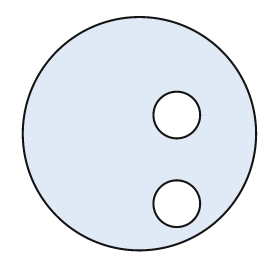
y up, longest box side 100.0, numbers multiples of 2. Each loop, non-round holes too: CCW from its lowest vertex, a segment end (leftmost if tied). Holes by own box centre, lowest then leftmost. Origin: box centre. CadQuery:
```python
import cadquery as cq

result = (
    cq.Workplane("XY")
    .moveTo(0.0, 0.0)
    .circle(50.0)
    .moveTo(16.0, -30.0)
    .circle(10.0)
    .moveTo(16.0, 8.0)
    .circle(10.0)
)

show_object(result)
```